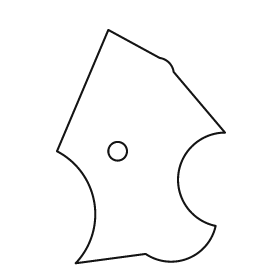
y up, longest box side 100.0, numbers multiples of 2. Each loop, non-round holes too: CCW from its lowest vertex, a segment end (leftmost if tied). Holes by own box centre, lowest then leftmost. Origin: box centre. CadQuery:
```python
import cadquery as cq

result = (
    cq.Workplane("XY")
    .moveTo(-28.0, -50.0)
    .lineTo(2.0, -46.0)
    .threePointArc((20.0, -48.0), (32.0, -34.0))
    .threePointArc((16.0, -12.0), (36.0, 6.0))
    .lineTo(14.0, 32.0)
    .threePointArc((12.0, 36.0), (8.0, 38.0))
    .lineTo(-14.0, 50.0)
    .lineTo(-36.0, -2.0)
    .threePointArc((-20.0, -24.0), (-28.0, -50.0))
    .close()
    .moveTo(-10.0, -2.0)
    .circle(4.0)
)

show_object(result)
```